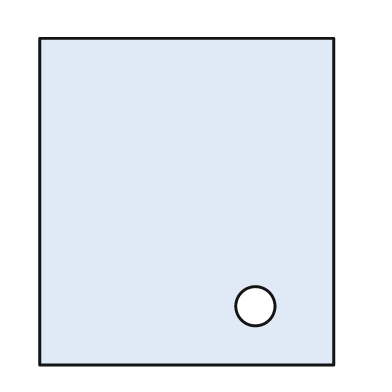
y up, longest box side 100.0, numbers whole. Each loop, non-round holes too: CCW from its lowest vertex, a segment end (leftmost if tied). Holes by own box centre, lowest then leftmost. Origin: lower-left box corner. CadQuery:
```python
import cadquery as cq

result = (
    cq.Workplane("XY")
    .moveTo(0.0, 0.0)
    .lineTo(90.0, 0.0)
    .lineTo(90.0, 100.0)
    .lineTo(0.0, 100.0)
    .close()
    .moveTo(66.0, 18.0)
    .circle(6.0)
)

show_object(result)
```